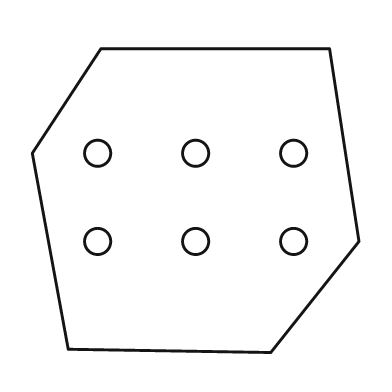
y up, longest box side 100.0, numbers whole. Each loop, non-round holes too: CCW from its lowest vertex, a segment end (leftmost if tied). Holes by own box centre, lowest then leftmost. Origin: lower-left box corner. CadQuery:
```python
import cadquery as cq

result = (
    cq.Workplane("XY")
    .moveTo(73.0, 0.0)
    .lineTo(100.0, 34.0)
    .lineTo(91.0, 93.0)
    .lineTo(21.0, 93.0)
    .lineTo(0.0, 61.0)
    .lineTo(11.0, 1.0)
    .close()
    .moveTo(20.0, 34.0)
    .circle(4.0)
    .moveTo(50.0, 34.0)
    .circle(4.0)
    .moveTo(80.0, 34.0)
    .circle(4.0)
    .moveTo(20.0, 61.0)
    .circle(4.0)
    .moveTo(50.0, 61.0)
    .circle(4.0)
    .moveTo(80.0, 61.0)
    .circle(4.0)
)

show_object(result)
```